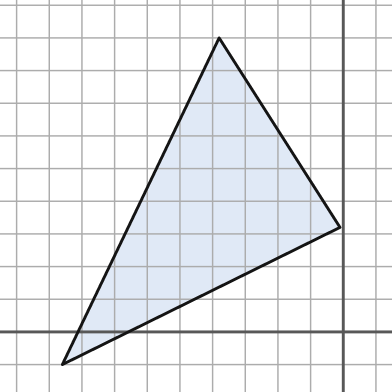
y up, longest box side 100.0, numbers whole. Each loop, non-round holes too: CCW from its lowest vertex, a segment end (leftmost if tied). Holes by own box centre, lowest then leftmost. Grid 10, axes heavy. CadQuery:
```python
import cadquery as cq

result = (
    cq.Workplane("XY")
    .moveTo(-86.0, -10.0)
    .lineTo(-1.0, 32.0)
    .lineTo(-38.0, 90.0)
    .close()
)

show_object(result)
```